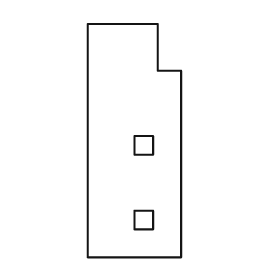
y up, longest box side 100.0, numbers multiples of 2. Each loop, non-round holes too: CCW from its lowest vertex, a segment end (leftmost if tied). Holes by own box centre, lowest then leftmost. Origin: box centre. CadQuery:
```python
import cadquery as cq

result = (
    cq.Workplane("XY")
    .moveTo(-20.0, -50.0)
    .lineTo(20.0, -50.0)
    .lineTo(20.0, 30.0)
    .lineTo(10.0, 30.0)
    .lineTo(10.0, 50.0)
    .lineTo(-20.0, 50.0)
    .close()
    .moveTo(0.0, -38.0)
    .lineTo(8.0, -38.0)
    .lineTo(8.0, -30.0)
    .lineTo(0.0, -30.0)
    .close()
    .moveTo(0.0, -6.0)
    .lineTo(8.0, -6.0)
    .lineTo(8.0, 2.0)
    .lineTo(0.0, 2.0)
    .close()
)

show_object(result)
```